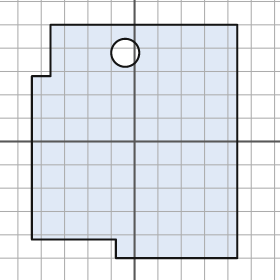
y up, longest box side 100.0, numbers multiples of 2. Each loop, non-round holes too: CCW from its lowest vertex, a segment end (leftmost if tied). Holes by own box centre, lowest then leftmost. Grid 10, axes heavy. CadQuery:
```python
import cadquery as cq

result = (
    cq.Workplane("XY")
    .moveTo(-8.0, -50.0)
    .lineTo(44.0, -50.0)
    .lineTo(44.0, 50.0)
    .lineTo(-36.0, 50.0)
    .lineTo(-36.0, 28.0)
    .lineTo(-44.0, 28.0)
    .lineTo(-44.0, -42.0)
    .lineTo(-8.0, -42.0)
    .close()
    .moveTo(-4.0, 38.0)
    .circle(6.0)
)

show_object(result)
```